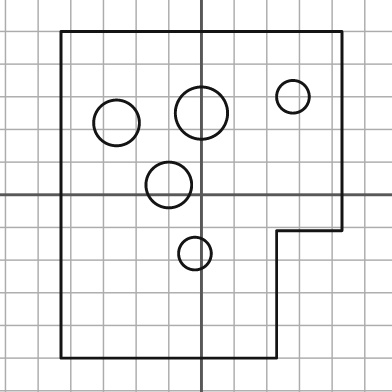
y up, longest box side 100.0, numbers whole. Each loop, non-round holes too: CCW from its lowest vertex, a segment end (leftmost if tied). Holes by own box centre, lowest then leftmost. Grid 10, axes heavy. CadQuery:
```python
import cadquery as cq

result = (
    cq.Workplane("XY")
    .moveTo(-43.0, -50.0)
    .lineTo(23.0, -50.0)
    .lineTo(23.0, -11.0)
    .lineTo(43.0, -11.0)
    .lineTo(43.0, 50.0)
    .lineTo(-43.0, 50.0)
    .close()
    .moveTo(-2.0, -18.0)
    .circle(5.0)
    .moveTo(-10.0, 3.0)
    .circle(7.0)
    .moveTo(-26.0, 22.0)
    .circle(7.0)
    .moveTo(0.0, 25.0)
    .circle(8.0)
    .moveTo(28.0, 30.0)
    .circle(5.0)
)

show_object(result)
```